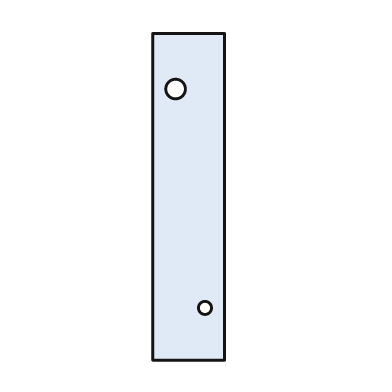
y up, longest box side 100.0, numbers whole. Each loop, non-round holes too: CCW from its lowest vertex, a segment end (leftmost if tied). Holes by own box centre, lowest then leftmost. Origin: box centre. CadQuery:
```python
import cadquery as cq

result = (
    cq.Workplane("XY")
    .moveTo(-11.0, -50.0)
    .lineTo(11.0, -50.0)
    .lineTo(11.0, 50.0)
    .lineTo(-11.0, 50.0)
    .close()
    .moveTo(5.0, -34.0)
    .circle(2.0)
    .moveTo(-4.0, 33.0)
    .circle(3.0)
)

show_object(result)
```